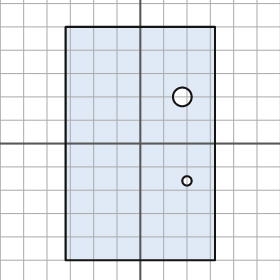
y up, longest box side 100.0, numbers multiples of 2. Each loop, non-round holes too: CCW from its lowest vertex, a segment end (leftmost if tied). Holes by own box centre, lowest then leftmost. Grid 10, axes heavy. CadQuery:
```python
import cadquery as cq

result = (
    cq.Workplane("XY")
    .moveTo(-32.0, -50.0)
    .lineTo(32.0, -50.0)
    .lineTo(32.0, 50.0)
    .lineTo(-32.0, 50.0)
    .close()
    .moveTo(20.0, -16.0)
    .circle(2.0)
    .moveTo(18.0, 20.0)
    .circle(4.0)
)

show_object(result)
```